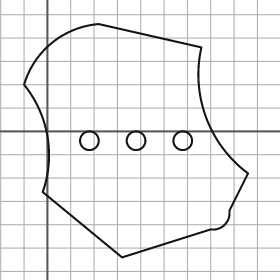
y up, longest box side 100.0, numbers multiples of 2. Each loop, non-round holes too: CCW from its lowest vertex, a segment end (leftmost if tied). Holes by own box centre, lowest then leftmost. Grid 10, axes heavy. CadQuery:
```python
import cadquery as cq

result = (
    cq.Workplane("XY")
    .moveTo(32.0, -54.0)
    .lineTo(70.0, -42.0)
    .threePointArc((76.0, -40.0), (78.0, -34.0))
    .lineTo(86.0, -18.0)
    .threePointArc((68.0, 6.0), (66.0, 36.0))
    .lineTo(22.0, 46.0)
    .threePointArc((2.0, 38.0), (-10.0, 20.0))
    .threePointArc((0.0, -2.0), (-2.0, -26.0))
    .close()
    .moveTo(18.0, -4.0)
    .circle(4.0)
    .moveTo(38.0, -4.0)
    .circle(4.0)
    .moveTo(58.0, -4.0)
    .circle(4.0)
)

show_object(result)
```